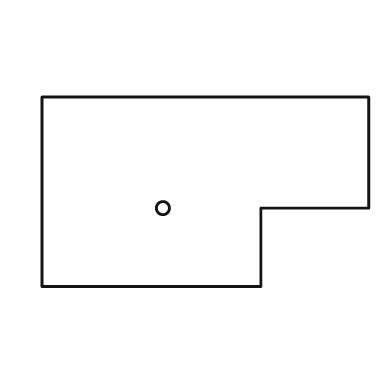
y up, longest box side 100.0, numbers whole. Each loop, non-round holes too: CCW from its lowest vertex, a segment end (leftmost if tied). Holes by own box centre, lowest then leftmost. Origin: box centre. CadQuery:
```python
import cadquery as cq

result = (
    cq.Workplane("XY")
    .moveTo(-50.0, -29.0)
    .lineTo(17.0, -29.0)
    .lineTo(17.0, -5.0)
    .lineTo(50.0, -5.0)
    .lineTo(50.0, 29.0)
    .lineTo(-50.0, 29.0)
    .close()
    .moveTo(-13.0, -5.0)
    .circle(2.0)
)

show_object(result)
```